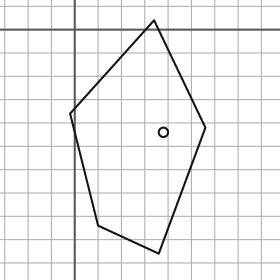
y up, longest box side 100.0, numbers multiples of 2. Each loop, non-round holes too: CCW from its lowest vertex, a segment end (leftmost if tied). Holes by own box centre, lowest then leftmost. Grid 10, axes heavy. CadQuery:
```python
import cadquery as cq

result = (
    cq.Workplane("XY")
    .moveTo(36.0, -96.0)
    .lineTo(56.0, -42.0)
    .lineTo(34.0, 4.0)
    .lineTo(-2.0, -36.0)
    .lineTo(10.0, -84.0)
    .close()
    .moveTo(38.0, -44.0)
    .circle(2.0)
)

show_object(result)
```